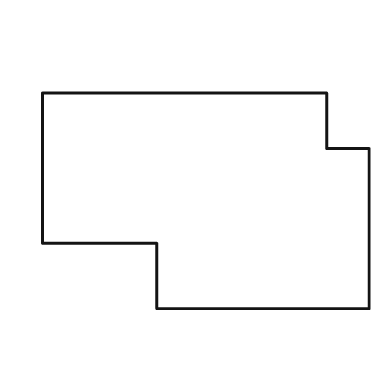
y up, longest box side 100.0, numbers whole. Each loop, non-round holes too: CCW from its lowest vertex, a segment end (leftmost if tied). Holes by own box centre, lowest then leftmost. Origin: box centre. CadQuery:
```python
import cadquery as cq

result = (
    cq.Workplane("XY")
    .moveTo(-15.0, -33.0)
    .lineTo(50.0, -33.0)
    .lineTo(50.0, 16.0)
    .lineTo(37.0, 16.0)
    .lineTo(37.0, 33.0)
    .lineTo(-50.0, 33.0)
    .lineTo(-50.0, -13.0)
    .lineTo(-15.0, -13.0)
    .close()
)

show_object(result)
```